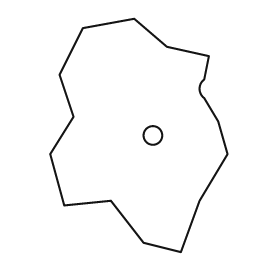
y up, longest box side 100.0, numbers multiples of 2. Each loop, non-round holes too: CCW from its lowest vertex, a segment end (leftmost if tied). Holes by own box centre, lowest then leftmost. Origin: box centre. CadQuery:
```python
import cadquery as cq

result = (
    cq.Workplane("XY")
    .moveTo(18.0, -50.0)
    .lineTo(26.0, -28.0)
    .lineTo(38.0, -8.0)
    .lineTo(34.0, 6.0)
    .lineTo(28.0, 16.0)
    .threePointArc((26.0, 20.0), (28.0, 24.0))
    .lineTo(30.0, 34.0)
    .lineTo(12.0, 38.0)
    .lineTo(-2.0, 50.0)
    .lineTo(-24.0, 46.0)
    .lineTo(-34.0, 26.0)
    .lineTo(-28.0, 8.0)
    .lineTo(-38.0, -8.0)
    .lineTo(-32.0, -30.0)
    .lineTo(-12.0, -28.0)
    .lineTo(2.0, -46.0)
    .close()
    .moveTo(6.0, 0.0)
    .circle(4.0)
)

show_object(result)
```